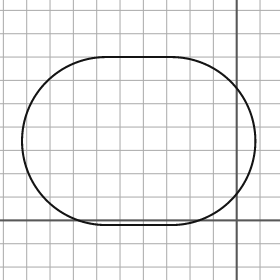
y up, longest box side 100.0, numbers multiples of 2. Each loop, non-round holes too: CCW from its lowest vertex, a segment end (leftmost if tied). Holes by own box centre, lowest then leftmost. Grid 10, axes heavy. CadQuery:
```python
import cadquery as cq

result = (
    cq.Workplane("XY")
    .moveTo(-56.0, -2.0)
    .lineTo(-28.0, -2.0)
    .threePointArc((8.0, 34.0), (-28.0, 70.0))
    .lineTo(-56.0, 70.0)
    .threePointArc((-92.0, 34.0), (-56.0, -2.0))
    .close()
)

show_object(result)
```